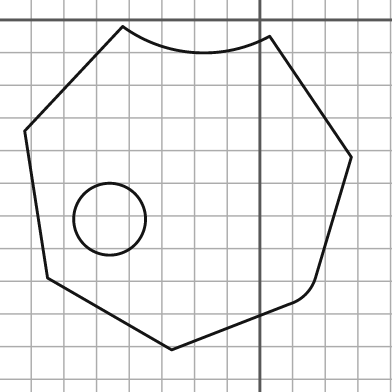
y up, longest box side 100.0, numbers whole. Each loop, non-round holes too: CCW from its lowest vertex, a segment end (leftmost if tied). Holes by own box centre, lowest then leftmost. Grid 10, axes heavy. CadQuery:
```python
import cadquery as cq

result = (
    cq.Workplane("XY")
    .moveTo(-27.0, -101.0)
    .lineTo(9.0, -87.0)
    .threePointArc((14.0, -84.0), (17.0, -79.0))
    .lineTo(28.0, -42.0)
    .lineTo(3.0, -5.0)
    .threePointArc((-20.0, -10.0), (-42.0, -2.0))
    .lineTo(-72.0, -34.0)
    .lineTo(-65.0, -79.0)
    .close()
    .moveTo(-46.0, -61.0)
    .circle(11.0)
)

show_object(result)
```